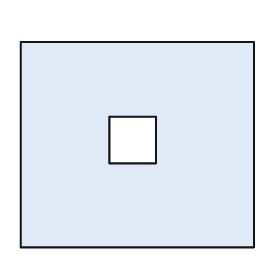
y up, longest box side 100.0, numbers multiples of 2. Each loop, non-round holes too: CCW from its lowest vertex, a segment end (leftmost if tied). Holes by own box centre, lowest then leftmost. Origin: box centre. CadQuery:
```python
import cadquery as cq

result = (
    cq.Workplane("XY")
    .moveTo(-50.0, -44.0)
    .lineTo(50.0, -44.0)
    .lineTo(50.0, 44.0)
    .lineTo(-50.0, 44.0)
    .close()
    .moveTo(-12.0, -8.0)
    .lineTo(8.0, -8.0)
    .lineTo(8.0, 12.0)
    .lineTo(-12.0, 12.0)
    .close()
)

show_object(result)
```